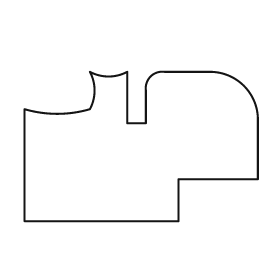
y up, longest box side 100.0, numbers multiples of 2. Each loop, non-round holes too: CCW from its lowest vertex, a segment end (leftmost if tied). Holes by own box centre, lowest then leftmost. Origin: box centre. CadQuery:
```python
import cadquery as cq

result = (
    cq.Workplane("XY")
    .moveTo(-50.0, -32.0)
    .lineTo(16.0, -32.0)
    .lineTo(16.0, -14.0)
    .lineTo(50.0, -14.0)
    .lineTo(50.0, 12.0)
    .threePointArc((44.0, 26.0), (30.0, 32.0))
    .lineTo(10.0, 32.0)
    .threePointArc((4.0, 30.0), (2.0, 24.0))
    .lineTo(2.0, 10.0)
    .lineTo(-6.0, 10.0)
    .lineTo(-6.0, 32.0)
    .threePointArc((-14.0, 30.0), (-22.0, 32.0))
    .threePointArc((-20.0, 24.0), (-22.0, 16.0))
    .threePointArc((-36.0, 14.0), (-50.0, 16.0))
    .close()
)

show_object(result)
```